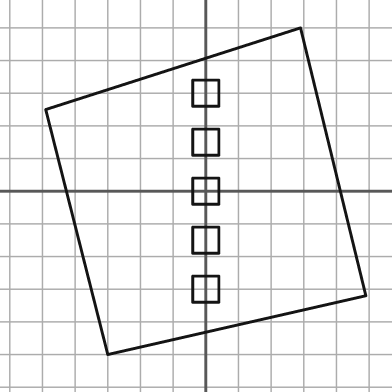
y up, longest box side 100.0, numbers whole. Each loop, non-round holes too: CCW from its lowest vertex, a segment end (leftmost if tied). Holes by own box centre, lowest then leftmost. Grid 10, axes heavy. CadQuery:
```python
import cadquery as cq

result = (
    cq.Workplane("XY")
    .moveTo(-30.0, -50.0)
    .lineTo(49.0, -32.0)
    .lineTo(29.0, 50.0)
    .lineTo(-49.0, 25.0)
    .close()
    .moveTo(-4.0, -34.0)
    .lineTo(4.0, -34.0)
    .lineTo(4.0, -26.0)
    .lineTo(-4.0, -26.0)
    .close()
    .moveTo(-4.0, -19.0)
    .lineTo(4.0, -19.0)
    .lineTo(4.0, -11.0)
    .lineTo(-4.0, -11.0)
    .close()
    .moveTo(-4.0, -4.0)
    .lineTo(4.0, -4.0)
    .lineTo(4.0, 4.0)
    .lineTo(-4.0, 4.0)
    .close()
    .moveTo(-4.0, 11.0)
    .lineTo(4.0, 11.0)
    .lineTo(4.0, 19.0)
    .lineTo(-4.0, 19.0)
    .close()
    .moveTo(-4.0, 26.0)
    .lineTo(4.0, 26.0)
    .lineTo(4.0, 34.0)
    .lineTo(-4.0, 34.0)
    .close()
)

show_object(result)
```